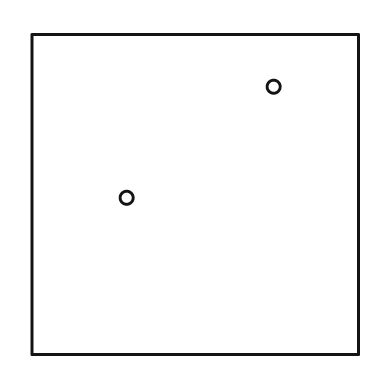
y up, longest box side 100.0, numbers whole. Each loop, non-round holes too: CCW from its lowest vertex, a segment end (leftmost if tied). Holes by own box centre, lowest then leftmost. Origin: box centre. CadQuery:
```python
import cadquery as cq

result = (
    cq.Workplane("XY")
    .moveTo(-50.0, -49.0)
    .lineTo(50.0, -49.0)
    .lineTo(50.0, 49.0)
    .lineTo(-50.0, 49.0)
    .close()
    .moveTo(-21.0, -1.0)
    .circle(2.0)
    .moveTo(24.0, 33.0)
    .circle(2.0)
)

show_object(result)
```